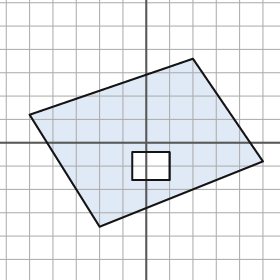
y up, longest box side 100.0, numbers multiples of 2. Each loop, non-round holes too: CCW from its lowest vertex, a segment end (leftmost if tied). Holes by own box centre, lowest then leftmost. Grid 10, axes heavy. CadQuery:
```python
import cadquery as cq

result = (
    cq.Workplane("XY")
    .moveTo(-20.0, -36.0)
    .lineTo(50.0, -8.0)
    .lineTo(20.0, 36.0)
    .lineTo(-50.0, 12.0)
    .close()
    .moveTo(-6.0, -16.0)
    .lineTo(10.0, -16.0)
    .lineTo(10.0, -4.0)
    .lineTo(-6.0, -4.0)
    .close()
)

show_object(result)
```